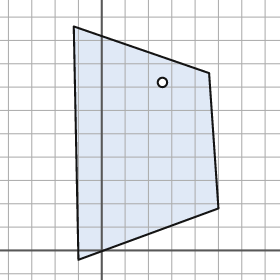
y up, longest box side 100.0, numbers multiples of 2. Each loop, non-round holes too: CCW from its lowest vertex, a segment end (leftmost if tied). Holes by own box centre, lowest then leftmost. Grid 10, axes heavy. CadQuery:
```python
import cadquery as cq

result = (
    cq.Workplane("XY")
    .moveTo(-10.0, -4.0)
    .lineTo(50.0, 18.0)
    .lineTo(46.0, 76.0)
    .lineTo(-12.0, 96.0)
    .close()
    .moveTo(26.0, 72.0)
    .circle(2.0)
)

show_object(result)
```